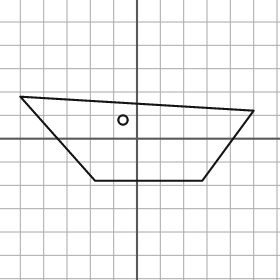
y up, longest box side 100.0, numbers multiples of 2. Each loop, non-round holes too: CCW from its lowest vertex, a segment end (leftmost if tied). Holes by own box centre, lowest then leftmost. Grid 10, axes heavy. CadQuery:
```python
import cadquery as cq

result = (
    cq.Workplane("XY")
    .moveTo(-18.0, -18.0)
    .lineTo(28.0, -18.0)
    .lineTo(50.0, 12.0)
    .lineTo(-50.0, 18.0)
    .close()
    .moveTo(-6.0, 8.0)
    .circle(2.0)
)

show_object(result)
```